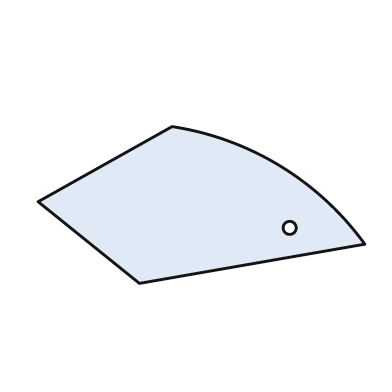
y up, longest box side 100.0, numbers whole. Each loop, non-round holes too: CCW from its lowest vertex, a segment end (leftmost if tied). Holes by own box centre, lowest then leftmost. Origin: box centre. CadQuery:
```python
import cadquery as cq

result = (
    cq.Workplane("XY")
    .moveTo(-19.0, -24.0)
    .lineTo(50.0, -12.0)
    .threePointArc((24.0, 12.0), (-9.0, 24.0))
    .lineTo(-50.0, 1.0)
    .close()
    .moveTo(27.0, -7.0)
    .circle(2.0)
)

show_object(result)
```